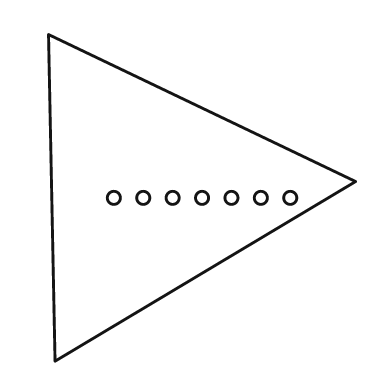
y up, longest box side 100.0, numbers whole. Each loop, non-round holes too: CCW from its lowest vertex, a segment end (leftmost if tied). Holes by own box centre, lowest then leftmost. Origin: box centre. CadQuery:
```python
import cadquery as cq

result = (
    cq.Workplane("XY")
    .moveTo(-45.0, -50.0)
    .lineTo(47.0, 5.0)
    .lineTo(-47.0, 50.0)
    .close()
    .moveTo(-27.0, 0.0)
    .circle(2.0)
    .moveTo(-18.0, 0.0)
    .circle(2.0)
    .moveTo(-9.0, 0.0)
    .circle(2.0)
    .moveTo(0.0, 0.0)
    .circle(2.0)
    .moveTo(9.0, 0.0)
    .circle(2.0)
    .moveTo(18.0, 0.0)
    .circle(2.0)
    .moveTo(27.0, 0.0)
    .circle(2.0)
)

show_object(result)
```